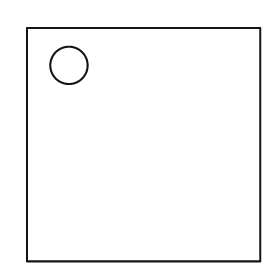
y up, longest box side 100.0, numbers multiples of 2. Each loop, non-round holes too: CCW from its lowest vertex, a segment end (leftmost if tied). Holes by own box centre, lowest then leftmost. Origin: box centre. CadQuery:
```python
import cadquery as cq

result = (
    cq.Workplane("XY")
    .moveTo(-50.0, -50.0)
    .lineTo(50.0, -50.0)
    .lineTo(50.0, 50.0)
    .lineTo(-50.0, 50.0)
    .close()
    .moveTo(-32.0, 34.0)
    .circle(8.0)
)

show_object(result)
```